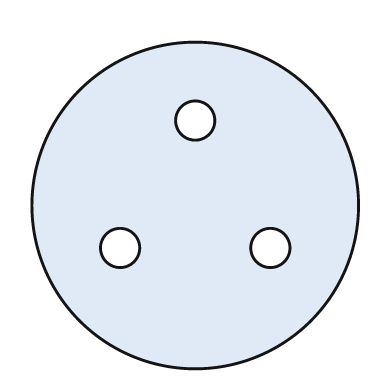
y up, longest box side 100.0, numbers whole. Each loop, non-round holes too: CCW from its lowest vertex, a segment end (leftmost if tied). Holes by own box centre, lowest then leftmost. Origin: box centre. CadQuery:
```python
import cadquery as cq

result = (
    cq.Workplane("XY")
    .moveTo(0.0, 0.0)
    .circle(50.0)
    .moveTo(-23.0, -13.0)
    .circle(6.0)
    .moveTo(23.0, -13.0)
    .circle(6.0)
    .moveTo(0.0, 26.0)
    .circle(6.0)
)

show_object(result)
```